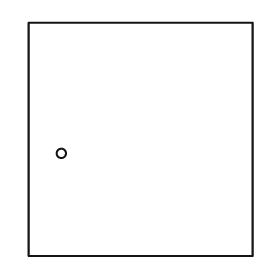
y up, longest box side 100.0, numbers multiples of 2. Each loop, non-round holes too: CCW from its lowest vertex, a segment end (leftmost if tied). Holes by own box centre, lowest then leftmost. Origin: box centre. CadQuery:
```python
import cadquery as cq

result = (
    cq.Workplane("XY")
    .moveTo(-48.0, -50.0)
    .lineTo(48.0, -50.0)
    .lineTo(48.0, 50.0)
    .lineTo(-48.0, 50.0)
    .close()
    .moveTo(-34.0, -6.0)
    .circle(2.0)
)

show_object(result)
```